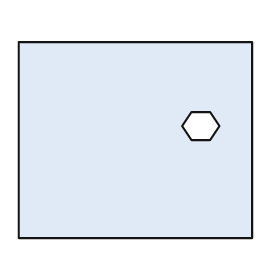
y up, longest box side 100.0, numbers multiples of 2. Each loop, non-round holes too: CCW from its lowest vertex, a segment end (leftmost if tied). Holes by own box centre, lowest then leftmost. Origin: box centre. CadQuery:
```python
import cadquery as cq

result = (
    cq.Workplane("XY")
    .moveTo(-50.0, -42.0)
    .lineTo(50.0, -42.0)
    .lineTo(50.0, 42.0)
    .lineTo(-50.0, 42.0)
    .close()
    .moveTo(24.0, 0.0)
    .lineTo(32.0, 0.0)
    .lineTo(36.0, 6.0)
    .lineTo(32.0, 12.0)
    .lineTo(24.0, 12.0)
    .lineTo(20.0, 6.0)
    .close()
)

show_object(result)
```